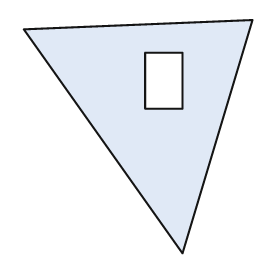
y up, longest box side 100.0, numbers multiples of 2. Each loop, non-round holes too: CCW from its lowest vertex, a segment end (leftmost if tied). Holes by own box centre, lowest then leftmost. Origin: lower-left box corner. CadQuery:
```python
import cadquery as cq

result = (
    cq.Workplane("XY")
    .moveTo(68.0, 0.0)
    .lineTo(98.0, 100.0)
    .lineTo(0.0, 96.0)
    .close()
    .moveTo(52.0, 62.0)
    .lineTo(68.0, 62.0)
    .lineTo(68.0, 86.0)
    .lineTo(52.0, 86.0)
    .close()
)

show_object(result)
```